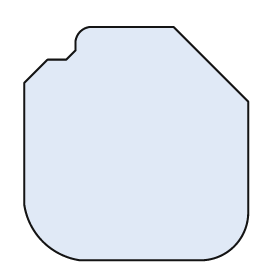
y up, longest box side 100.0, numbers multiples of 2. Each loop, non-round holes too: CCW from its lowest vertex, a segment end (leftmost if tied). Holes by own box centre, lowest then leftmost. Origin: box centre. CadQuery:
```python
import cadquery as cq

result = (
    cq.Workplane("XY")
    .moveTo(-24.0, -50.0)
    .lineTo(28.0, -50.0)
    .threePointArc((42.0, -44.0), (48.0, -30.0))
    .lineTo(48.0, 18.0)
    .lineTo(16.0, 50.0)
    .lineTo(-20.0, 50.0)
    .threePointArc((-24.0, 48.0), (-26.0, 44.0))
    .lineTo(-26.0, 40.0)
    .lineTo(-30.0, 36.0)
    .lineTo(-38.0, 36.0)
    .lineTo(-48.0, 26.0)
    .lineTo(-48.0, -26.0)
    .threePointArc((-40.0, -42.0), (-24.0, -50.0))
    .close()
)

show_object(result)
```